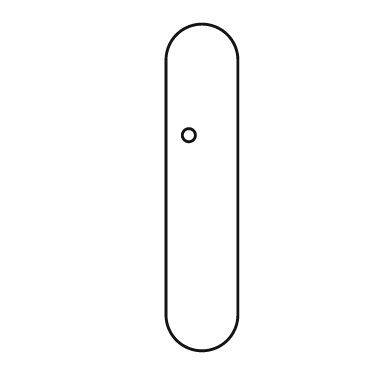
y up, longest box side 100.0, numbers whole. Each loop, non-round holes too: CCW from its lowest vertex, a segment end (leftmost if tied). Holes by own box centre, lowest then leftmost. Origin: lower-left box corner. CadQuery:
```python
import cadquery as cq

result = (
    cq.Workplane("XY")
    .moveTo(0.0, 11.0)
    .threePointArc((11.0, 0.0), (22.0, 11.0))
    .lineTo(22.0, 89.0)
    .threePointArc((11.0, 100.0), (0.0, 89.0))
    .close()
    .moveTo(7.0, 66.0)
    .circle(2.0)
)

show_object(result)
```